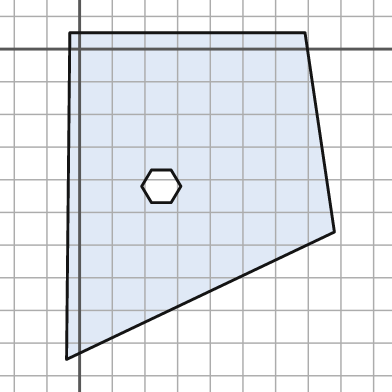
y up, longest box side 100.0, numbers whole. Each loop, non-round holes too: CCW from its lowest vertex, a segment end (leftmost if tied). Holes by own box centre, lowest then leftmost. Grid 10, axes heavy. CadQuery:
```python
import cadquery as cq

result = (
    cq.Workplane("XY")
    .moveTo(-4.0, -95.0)
    .lineTo(78.0, -56.0)
    .lineTo(69.0, 5.0)
    .lineTo(-3.0, 5.0)
    .close()
    .moveTo(22.0, -47.0)
    .lineTo(28.0, -47.0)
    .lineTo(31.0, -42.0)
    .lineTo(28.0, -37.0)
    .lineTo(22.0, -37.0)
    .lineTo(19.0, -42.0)
    .close()
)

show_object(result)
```